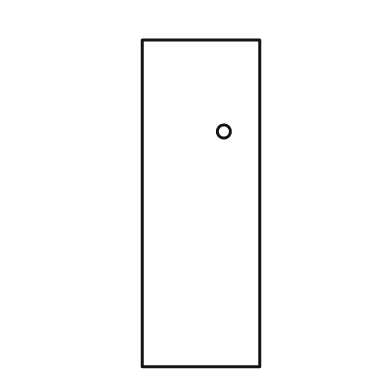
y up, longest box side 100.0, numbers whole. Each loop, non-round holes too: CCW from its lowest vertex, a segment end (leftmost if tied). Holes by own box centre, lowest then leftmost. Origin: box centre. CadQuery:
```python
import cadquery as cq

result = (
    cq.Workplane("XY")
    .moveTo(-18.0, -50.0)
    .lineTo(18.0, -50.0)
    .lineTo(18.0, 50.0)
    .lineTo(-18.0, 50.0)
    .close()
    .moveTo(7.0, 22.0)
    .circle(2.0)
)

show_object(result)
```